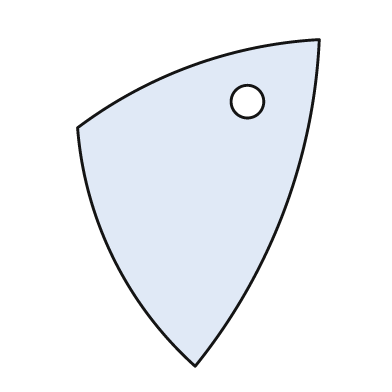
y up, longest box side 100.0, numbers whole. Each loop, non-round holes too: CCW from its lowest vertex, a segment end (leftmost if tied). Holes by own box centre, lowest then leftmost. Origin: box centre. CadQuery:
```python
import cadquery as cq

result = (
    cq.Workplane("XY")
    .moveTo(-1.0, -50.0)
    .threePointArc((26.0, -3.0), (37.0, 50.0))
    .threePointArc((-2.0, 42.0), (-37.0, 23.0))
    .threePointArc((-26.0, -17.0), (-1.0, -50.0))
    .close()
    .moveTo(15.0, 31.0)
    .circle(5.0)
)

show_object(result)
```